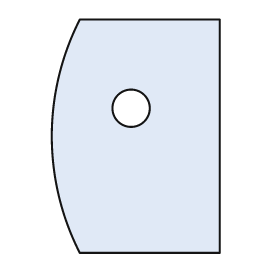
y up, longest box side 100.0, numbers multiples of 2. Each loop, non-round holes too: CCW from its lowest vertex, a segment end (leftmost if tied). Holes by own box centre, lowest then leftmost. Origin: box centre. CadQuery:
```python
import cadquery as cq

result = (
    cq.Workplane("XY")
    .moveTo(-24.0, -50.0)
    .lineTo(36.0, -50.0)
    .lineTo(36.0, 50.0)
    .lineTo(-24.0, 50.0)
    .threePointArc((-36.0, 0.0), (-24.0, -50.0))
    .close()
    .moveTo(-2.0, 12.0)
    .circle(8.0)
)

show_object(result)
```